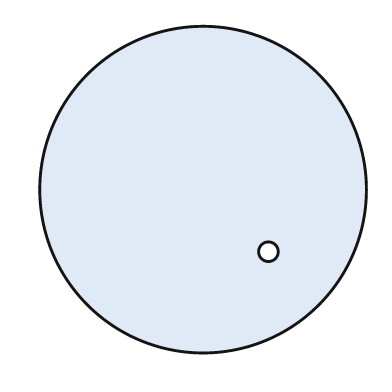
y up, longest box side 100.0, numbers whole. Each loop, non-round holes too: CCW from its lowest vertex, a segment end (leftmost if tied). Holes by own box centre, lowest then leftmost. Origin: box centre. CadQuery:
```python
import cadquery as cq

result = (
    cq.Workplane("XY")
    .moveTo(0.0, 0.0)
    .circle(50.0)
    .moveTo(20.0, -19.0)
    .circle(3.0)
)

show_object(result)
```